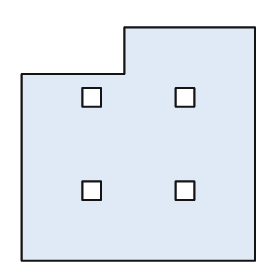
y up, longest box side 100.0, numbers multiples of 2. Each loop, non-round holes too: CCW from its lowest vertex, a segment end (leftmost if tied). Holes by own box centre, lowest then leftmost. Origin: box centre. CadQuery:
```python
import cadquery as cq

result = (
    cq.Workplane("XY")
    .moveTo(-50.0, -50.0)
    .lineTo(50.0, -50.0)
    .lineTo(50.0, 50.0)
    .lineTo(-6.0, 50.0)
    .lineTo(-6.0, 30.0)
    .lineTo(-50.0, 30.0)
    .close()
    .moveTo(-24.0, -24.0)
    .lineTo(-16.0, -24.0)
    .lineTo(-16.0, -16.0)
    .lineTo(-24.0, -16.0)
    .close()
    .moveTo(16.0, -24.0)
    .lineTo(24.0, -24.0)
    .lineTo(24.0, -16.0)
    .lineTo(16.0, -16.0)
    .close()
    .moveTo(-24.0, 16.0)
    .lineTo(-16.0, 16.0)
    .lineTo(-16.0, 24.0)
    .lineTo(-24.0, 24.0)
    .close()
    .moveTo(16.0, 16.0)
    .lineTo(24.0, 16.0)
    .lineTo(24.0, 24.0)
    .lineTo(16.0, 24.0)
    .close()
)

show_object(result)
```